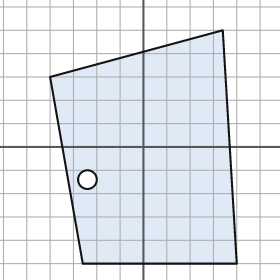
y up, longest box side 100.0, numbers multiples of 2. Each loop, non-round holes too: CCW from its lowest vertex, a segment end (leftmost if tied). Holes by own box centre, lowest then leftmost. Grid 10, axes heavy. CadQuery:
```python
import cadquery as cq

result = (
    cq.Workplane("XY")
    .moveTo(-26.0, -50.0)
    .lineTo(40.0, -50.0)
    .lineTo(34.0, 50.0)
    .lineTo(-40.0, 30.0)
    .close()
    .moveTo(-24.0, -14.0)
    .circle(4.0)
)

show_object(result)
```